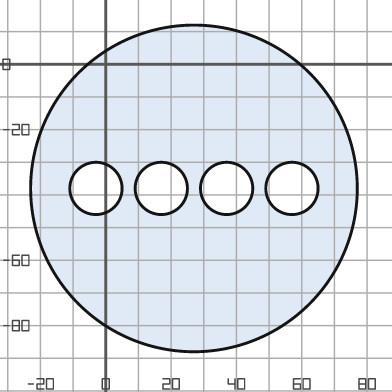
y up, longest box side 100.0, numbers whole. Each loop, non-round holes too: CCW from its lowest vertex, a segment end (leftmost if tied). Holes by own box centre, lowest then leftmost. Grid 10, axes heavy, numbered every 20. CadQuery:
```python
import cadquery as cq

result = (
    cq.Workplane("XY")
    .moveTo(27.0, -38.0)
    .circle(50.0)
    .moveTo(-3.0, -38.0)
    .circle(8.0)
    .moveTo(17.0, -38.0)
    .circle(8.0)
    .moveTo(37.0, -38.0)
    .circle(8.0)
    .moveTo(57.0, -38.0)
    .circle(8.0)
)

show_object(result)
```